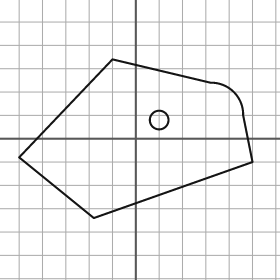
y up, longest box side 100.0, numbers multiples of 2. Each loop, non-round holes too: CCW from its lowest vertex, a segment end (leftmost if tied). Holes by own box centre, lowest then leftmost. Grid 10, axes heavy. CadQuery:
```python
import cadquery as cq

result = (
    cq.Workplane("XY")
    .moveTo(-18.0, -34.0)
    .lineTo(50.0, -10.0)
    .lineTo(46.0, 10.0)
    .threePointArc((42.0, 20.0), (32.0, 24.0))
    .lineTo(-10.0, 34.0)
    .lineTo(-50.0, -8.0)
    .close()
    .moveTo(10.0, 8.0)
    .circle(4.0)
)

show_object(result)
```